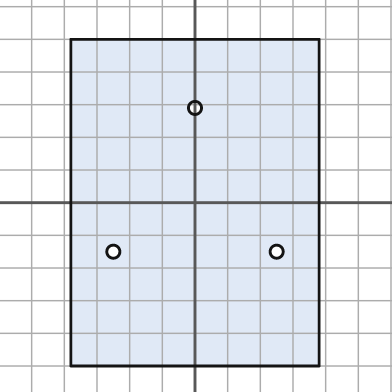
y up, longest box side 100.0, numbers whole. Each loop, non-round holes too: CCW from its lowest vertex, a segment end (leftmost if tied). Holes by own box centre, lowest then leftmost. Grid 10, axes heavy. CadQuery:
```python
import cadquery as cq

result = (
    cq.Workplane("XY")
    .moveTo(-38.0, -50.0)
    .lineTo(38.0, -50.0)
    .lineTo(38.0, 50.0)
    .lineTo(-38.0, 50.0)
    .close()
    .moveTo(-25.0, -15.0)
    .circle(2.0)
    .moveTo(25.0, -15.0)
    .circle(2.0)
    .moveTo(0.0, 29.0)
    .circle(2.0)
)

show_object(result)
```